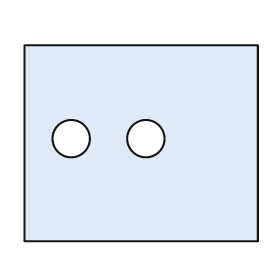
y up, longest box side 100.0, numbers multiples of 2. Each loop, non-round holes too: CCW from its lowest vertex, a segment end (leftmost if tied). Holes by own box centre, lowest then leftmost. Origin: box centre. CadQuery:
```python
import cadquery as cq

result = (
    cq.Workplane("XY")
    .moveTo(-50.0, -42.0)
    .lineTo(50.0, -42.0)
    .lineTo(50.0, 42.0)
    .lineTo(-50.0, 42.0)
    .close()
    .moveTo(-30.0, 2.0)
    .circle(8.0)
    .moveTo(2.0, 2.0)
    .circle(8.0)
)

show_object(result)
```